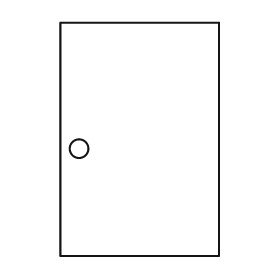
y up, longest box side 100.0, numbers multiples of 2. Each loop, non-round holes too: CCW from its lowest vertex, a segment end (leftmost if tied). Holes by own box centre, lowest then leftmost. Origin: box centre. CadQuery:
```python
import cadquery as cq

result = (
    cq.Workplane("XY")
    .moveTo(-34.0, -50.0)
    .lineTo(34.0, -50.0)
    .lineTo(34.0, 50.0)
    .lineTo(-34.0, 50.0)
    .close()
    .moveTo(-26.0, -4.0)
    .circle(4.0)
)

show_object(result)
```